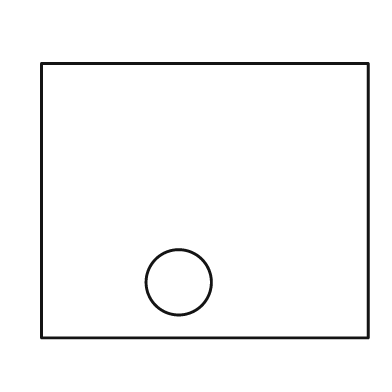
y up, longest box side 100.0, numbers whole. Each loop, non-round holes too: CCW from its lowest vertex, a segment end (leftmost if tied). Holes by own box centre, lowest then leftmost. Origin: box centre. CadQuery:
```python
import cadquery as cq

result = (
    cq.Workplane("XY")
    .moveTo(-50.0, -42.0)
    .lineTo(50.0, -42.0)
    .lineTo(50.0, 42.0)
    .lineTo(-50.0, 42.0)
    .close()
    .moveTo(-8.0, -25.0)
    .circle(10.0)
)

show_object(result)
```